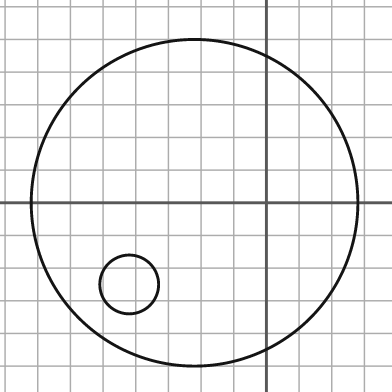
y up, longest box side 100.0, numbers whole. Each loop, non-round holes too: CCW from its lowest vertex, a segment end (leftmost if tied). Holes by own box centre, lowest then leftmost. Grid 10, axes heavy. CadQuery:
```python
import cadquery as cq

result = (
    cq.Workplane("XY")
    .moveTo(-22.0, 0.0)
    .circle(50.0)
    .moveTo(-42.0, -25.0)
    .circle(9.0)
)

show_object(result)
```